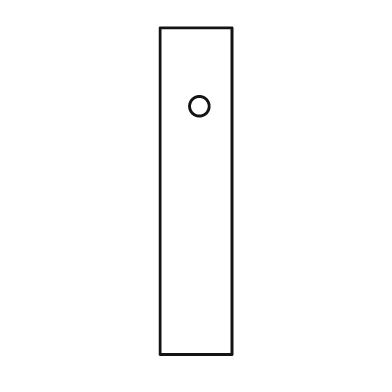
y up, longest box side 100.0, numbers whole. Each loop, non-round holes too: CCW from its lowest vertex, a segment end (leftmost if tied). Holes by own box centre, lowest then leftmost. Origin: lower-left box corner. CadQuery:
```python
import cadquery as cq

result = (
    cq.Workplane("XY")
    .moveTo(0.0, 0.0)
    .lineTo(22.0, 0.0)
    .lineTo(22.0, 100.0)
    .lineTo(0.0, 100.0)
    .close()
    .moveTo(12.0, 76.0)
    .circle(3.0)
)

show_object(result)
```